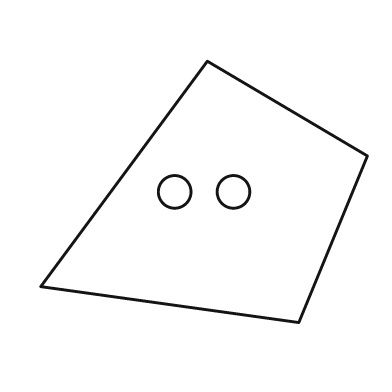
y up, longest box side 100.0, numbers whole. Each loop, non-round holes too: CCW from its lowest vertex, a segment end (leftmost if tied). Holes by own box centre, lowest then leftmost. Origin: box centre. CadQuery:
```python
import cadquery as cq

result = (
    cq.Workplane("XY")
    .moveTo(29.0, -40.0)
    .lineTo(50.0, 11.0)
    .lineTo(1.0, 40.0)
    .lineTo(-50.0, -29.0)
    .close()
    .moveTo(-9.0, 0.0)
    .circle(5.0)
    .moveTo(9.0, 0.0)
    .circle(5.0)
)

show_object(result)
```